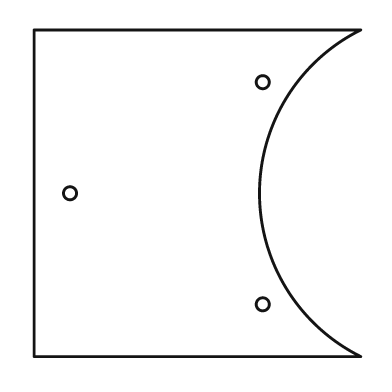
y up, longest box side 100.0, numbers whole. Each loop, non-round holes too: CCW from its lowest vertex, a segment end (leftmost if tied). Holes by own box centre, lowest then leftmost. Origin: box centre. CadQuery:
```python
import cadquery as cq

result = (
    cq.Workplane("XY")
    .moveTo(-50.0, -50.0)
    .lineTo(50.0, -50.0)
    .threePointArc((19.0, 0.0), (50.0, 50.0))
    .lineTo(-50.0, 50.0)
    .close()
    .moveTo(20.0, -34.0)
    .circle(2.0)
    .moveTo(-39.0, 0.0)
    .circle(2.0)
    .moveTo(20.0, 34.0)
    .circle(2.0)
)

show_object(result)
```